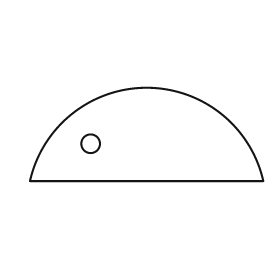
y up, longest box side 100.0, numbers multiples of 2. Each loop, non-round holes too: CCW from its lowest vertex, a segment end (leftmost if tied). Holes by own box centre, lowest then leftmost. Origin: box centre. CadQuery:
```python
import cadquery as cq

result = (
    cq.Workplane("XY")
    .moveTo(-50.0, -20.0)
    .lineTo(50.0, -20.0)
    .threePointArc((0.0, 20.0), (-50.0, -20.0))
    .close()
    .moveTo(-24.0, -4.0)
    .circle(4.0)
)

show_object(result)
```